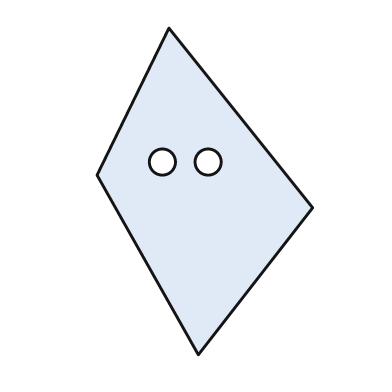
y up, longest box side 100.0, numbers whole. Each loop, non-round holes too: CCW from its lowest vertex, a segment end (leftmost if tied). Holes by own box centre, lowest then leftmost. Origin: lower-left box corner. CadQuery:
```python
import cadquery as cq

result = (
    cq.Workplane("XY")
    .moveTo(31.0, 0.0)
    .lineTo(66.0, 45.0)
    .lineTo(22.0, 100.0)
    .lineTo(0.0, 55.0)
    .close()
    .moveTo(20.0, 59.0)
    .circle(4.0)
    .moveTo(34.0, 59.0)
    .circle(4.0)
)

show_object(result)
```